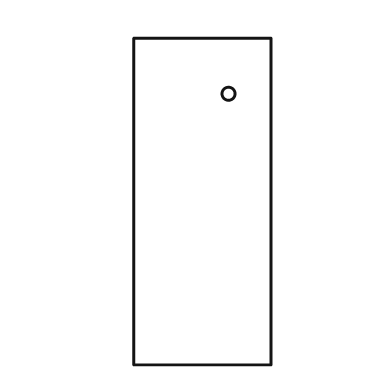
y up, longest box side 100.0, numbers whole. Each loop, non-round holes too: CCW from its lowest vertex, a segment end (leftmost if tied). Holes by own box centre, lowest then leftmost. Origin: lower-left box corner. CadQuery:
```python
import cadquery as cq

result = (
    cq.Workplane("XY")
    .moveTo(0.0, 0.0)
    .lineTo(42.0, 0.0)
    .lineTo(42.0, 100.0)
    .lineTo(0.0, 100.0)
    .close()
    .moveTo(29.0, 83.0)
    .circle(2.0)
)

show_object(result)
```